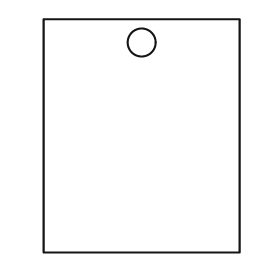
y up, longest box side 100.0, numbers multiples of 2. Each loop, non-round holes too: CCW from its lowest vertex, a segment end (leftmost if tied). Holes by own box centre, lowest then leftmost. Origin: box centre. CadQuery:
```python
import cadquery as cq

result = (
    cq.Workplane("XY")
    .moveTo(-42.0, -50.0)
    .lineTo(42.0, -50.0)
    .lineTo(42.0, 50.0)
    .lineTo(-42.0, 50.0)
    .close()
    .moveTo(0.0, 40.0)
    .circle(6.0)
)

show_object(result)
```